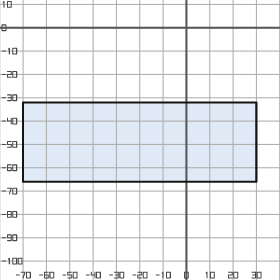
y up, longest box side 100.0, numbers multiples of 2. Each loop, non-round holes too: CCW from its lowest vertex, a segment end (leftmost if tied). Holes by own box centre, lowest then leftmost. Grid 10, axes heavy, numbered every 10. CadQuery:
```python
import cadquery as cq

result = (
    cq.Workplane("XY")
    .moveTo(-70.0, -66.0)
    .lineTo(30.0, -66.0)
    .lineTo(30.0, -32.0)
    .lineTo(-70.0, -32.0)
    .close()
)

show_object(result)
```